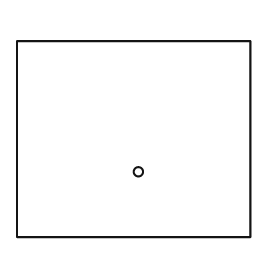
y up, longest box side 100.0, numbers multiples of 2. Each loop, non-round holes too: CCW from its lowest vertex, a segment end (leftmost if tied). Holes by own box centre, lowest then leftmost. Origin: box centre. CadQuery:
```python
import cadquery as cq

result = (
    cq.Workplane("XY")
    .moveTo(-50.0, -42.0)
    .lineTo(50.0, -42.0)
    .lineTo(50.0, 42.0)
    .lineTo(-50.0, 42.0)
    .close()
    .moveTo(2.0, -14.0)
    .circle(2.0)
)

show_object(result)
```